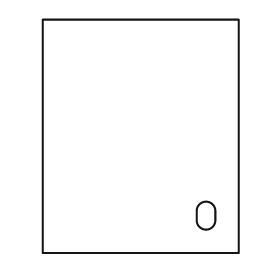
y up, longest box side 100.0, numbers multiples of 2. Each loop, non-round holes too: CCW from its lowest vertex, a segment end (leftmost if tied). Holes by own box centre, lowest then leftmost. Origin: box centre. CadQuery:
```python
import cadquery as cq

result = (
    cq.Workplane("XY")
    .moveTo(-42.0, -50.0)
    .lineTo(42.0, -50.0)
    .lineTo(42.0, 50.0)
    .lineTo(-42.0, 50.0)
    .close()
    .moveTo(24.0, -36.0)
    .threePointArc((28.0, -40.0), (32.0, -36.0))
    .lineTo(32.0, -32.0)
    .threePointArc((28.0, -28.0), (24.0, -32.0))
    .close()
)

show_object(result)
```